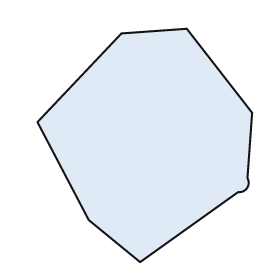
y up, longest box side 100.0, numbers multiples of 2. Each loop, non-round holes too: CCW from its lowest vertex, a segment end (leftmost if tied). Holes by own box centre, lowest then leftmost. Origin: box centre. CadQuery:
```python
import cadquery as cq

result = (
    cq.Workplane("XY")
    .moveTo(-2.0, -50.0)
    .lineTo(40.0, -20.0)
    .threePointArc((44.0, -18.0), (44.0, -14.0))
    .lineTo(46.0, 14.0)
    .lineTo(18.0, 50.0)
    .lineTo(-10.0, 48.0)
    .lineTo(-46.0, 10.0)
    .lineTo(-24.0, -32.0)
    .close()
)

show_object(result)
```